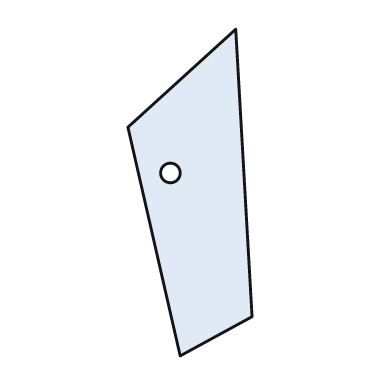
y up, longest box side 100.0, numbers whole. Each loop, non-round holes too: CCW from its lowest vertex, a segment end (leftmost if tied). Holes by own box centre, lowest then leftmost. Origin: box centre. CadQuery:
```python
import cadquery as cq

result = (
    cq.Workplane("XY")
    .moveTo(-3.0, -50.0)
    .lineTo(19.0, -38.0)
    .lineTo(14.0, 50.0)
    .lineTo(-19.0, 20.0)
    .close()
    .moveTo(-6.0, 6.0)
    .circle(3.0)
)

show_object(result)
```